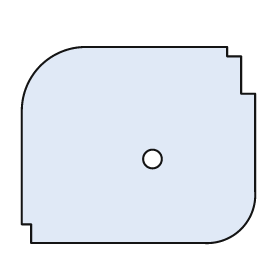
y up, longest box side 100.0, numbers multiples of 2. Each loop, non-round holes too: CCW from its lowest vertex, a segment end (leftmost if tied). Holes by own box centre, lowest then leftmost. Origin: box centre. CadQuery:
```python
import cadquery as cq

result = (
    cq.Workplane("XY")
    .moveTo(-46.0, -42.0)
    .lineTo(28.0, -42.0)
    .threePointArc((44.0, -36.0), (50.0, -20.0))
    .lineTo(50.0, 22.0)
    .lineTo(44.0, 22.0)
    .lineTo(44.0, 38.0)
    .lineTo(38.0, 38.0)
    .lineTo(38.0, 42.0)
    .lineTo(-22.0, 42.0)
    .threePointArc((-42.0, 34.0), (-50.0, 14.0))
    .lineTo(-50.0, -34.0)
    .lineTo(-46.0, -34.0)
    .close()
    .moveTo(6.0, -6.0)
    .circle(4.0)
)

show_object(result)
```